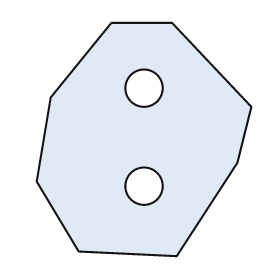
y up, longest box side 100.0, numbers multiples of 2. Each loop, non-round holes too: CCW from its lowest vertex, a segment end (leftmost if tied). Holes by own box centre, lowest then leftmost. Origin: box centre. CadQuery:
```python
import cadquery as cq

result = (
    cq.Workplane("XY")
    .moveTo(14.0, -50.0)
    .lineTo(40.0, -10.0)
    .lineTo(46.0, 14.0)
    .lineTo(12.0, 50.0)
    .lineTo(-14.0, 50.0)
    .lineTo(-40.0, 18.0)
    .lineTo(-46.0, -18.0)
    .lineTo(-28.0, -48.0)
    .close()
    .moveTo(0.0, -20.0)
    .circle(8.0)
    .moveTo(0.0, 22.0)
    .circle(8.0)
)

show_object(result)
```